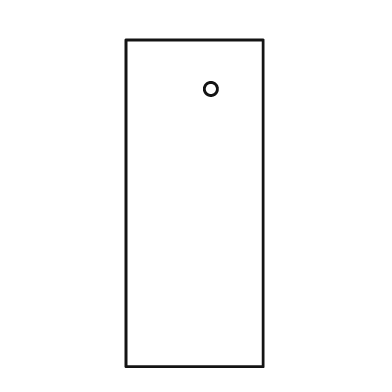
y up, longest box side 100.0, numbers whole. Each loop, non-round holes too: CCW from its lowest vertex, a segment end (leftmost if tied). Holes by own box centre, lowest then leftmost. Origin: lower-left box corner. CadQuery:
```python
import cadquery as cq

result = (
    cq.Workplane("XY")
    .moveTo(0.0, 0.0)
    .lineTo(42.0, 0.0)
    .lineTo(42.0, 100.0)
    .lineTo(0.0, 100.0)
    .close()
    .moveTo(26.0, 85.0)
    .circle(2.0)
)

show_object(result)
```